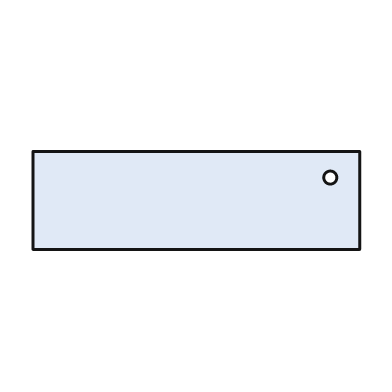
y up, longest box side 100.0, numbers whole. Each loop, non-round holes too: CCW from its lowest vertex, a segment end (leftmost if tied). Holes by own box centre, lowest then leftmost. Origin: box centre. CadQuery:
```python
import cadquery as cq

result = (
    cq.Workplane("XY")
    .moveTo(-50.0, -15.0)
    .lineTo(50.0, -15.0)
    .lineTo(50.0, 15.0)
    .lineTo(-50.0, 15.0)
    .close()
    .moveTo(41.0, 7.0)
    .circle(2.0)
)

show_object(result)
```